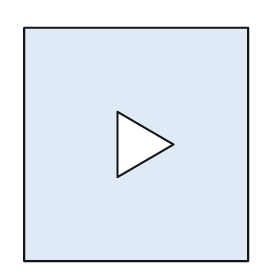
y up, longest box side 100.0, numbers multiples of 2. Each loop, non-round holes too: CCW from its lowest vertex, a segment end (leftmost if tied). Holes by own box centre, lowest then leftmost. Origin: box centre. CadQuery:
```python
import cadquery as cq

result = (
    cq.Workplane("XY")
    .moveTo(-48.0, -50.0)
    .lineTo(48.0, -50.0)
    .lineTo(48.0, 50.0)
    .lineTo(-48.0, 50.0)
    .close()
    .moveTo(-8.0, -14.0)
    .lineTo(16.0, 0.0)
    .lineTo(-8.0, 14.0)
    .close()
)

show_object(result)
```